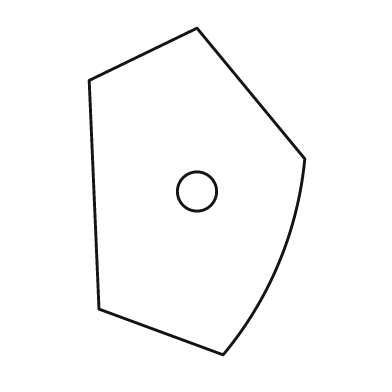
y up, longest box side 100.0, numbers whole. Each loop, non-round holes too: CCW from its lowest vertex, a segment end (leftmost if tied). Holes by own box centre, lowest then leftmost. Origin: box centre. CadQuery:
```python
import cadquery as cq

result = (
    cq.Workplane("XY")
    .moveTo(8.0, -50.0)
    .threePointArc((25.0, -22.0), (33.0, 10.0))
    .lineTo(0.0, 50.0)
    .lineTo(-33.0, 34.0)
    .lineTo(-30.0, -36.0)
    .close()
    .moveTo(0.0, 0.0)
    .circle(6.0)
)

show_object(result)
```